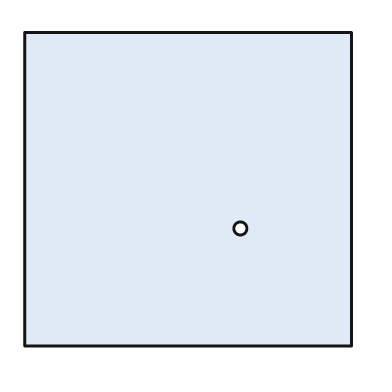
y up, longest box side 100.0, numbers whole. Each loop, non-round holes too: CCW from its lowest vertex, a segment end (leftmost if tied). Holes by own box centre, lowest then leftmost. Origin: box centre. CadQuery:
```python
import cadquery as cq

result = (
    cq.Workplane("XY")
    .moveTo(-50.0, -48.0)
    .lineTo(50.0, -48.0)
    .lineTo(50.0, 48.0)
    .lineTo(-50.0, 48.0)
    .close()
    .moveTo(16.0, -12.0)
    .circle(2.0)
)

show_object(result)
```